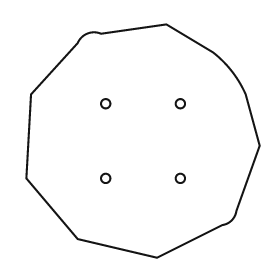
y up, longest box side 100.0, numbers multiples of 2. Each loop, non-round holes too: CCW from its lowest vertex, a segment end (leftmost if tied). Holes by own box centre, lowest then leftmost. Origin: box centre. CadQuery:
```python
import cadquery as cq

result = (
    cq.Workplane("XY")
    .moveTo(6.0, -50.0)
    .lineTo(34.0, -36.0)
    .threePointArc((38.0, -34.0), (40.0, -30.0))
    .lineTo(50.0, -2.0)
    .lineTo(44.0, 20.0)
    .threePointArc((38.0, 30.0), (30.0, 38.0))
    .lineTo(10.0, 50.0)
    .lineTo(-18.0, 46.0)
    .threePointArc((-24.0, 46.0), (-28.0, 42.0))
    .lineTo(-48.0, 20.0)
    .lineTo(-50.0, -16.0)
    .lineTo(-28.0, -42.0)
    .close()
    .moveTo(-16.0, -16.0)
    .circle(2.0)
    .moveTo(16.0, -16.0)
    .circle(2.0)
    .moveTo(-16.0, 16.0)
    .circle(2.0)
    .moveTo(16.0, 16.0)
    .circle(2.0)
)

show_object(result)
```